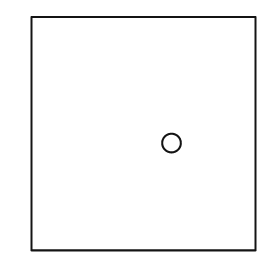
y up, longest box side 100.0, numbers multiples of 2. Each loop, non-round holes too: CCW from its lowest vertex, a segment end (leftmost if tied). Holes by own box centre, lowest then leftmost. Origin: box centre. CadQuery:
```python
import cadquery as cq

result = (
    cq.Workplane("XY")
    .moveTo(-48.0, -50.0)
    .lineTo(48.0, -50.0)
    .lineTo(48.0, 50.0)
    .lineTo(-48.0, 50.0)
    .close()
    .moveTo(12.0, -4.0)
    .circle(4.0)
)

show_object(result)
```